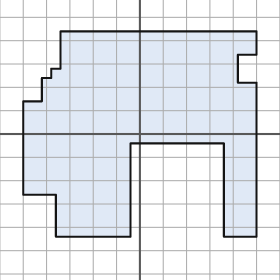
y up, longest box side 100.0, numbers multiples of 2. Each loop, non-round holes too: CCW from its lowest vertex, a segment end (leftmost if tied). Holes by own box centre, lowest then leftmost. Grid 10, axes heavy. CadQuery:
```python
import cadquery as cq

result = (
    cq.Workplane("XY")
    .moveTo(-36.0, -44.0)
    .lineTo(-4.0, -44.0)
    .lineTo(-4.0, -4.0)
    .lineTo(36.0, -4.0)
    .lineTo(36.0, -44.0)
    .lineTo(50.0, -44.0)
    .lineTo(50.0, 22.0)
    .lineTo(42.0, 22.0)
    .lineTo(42.0, 34.0)
    .lineTo(50.0, 34.0)
    .lineTo(50.0, 44.0)
    .lineTo(-34.0, 44.0)
    .lineTo(-34.0, 28.0)
    .lineTo(-38.0, 28.0)
    .lineTo(-38.0, 24.0)
    .lineTo(-42.0, 24.0)
    .lineTo(-42.0, 14.0)
    .lineTo(-50.0, 14.0)
    .lineTo(-50.0, -26.0)
    .lineTo(-36.0, -26.0)
    .close()
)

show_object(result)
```